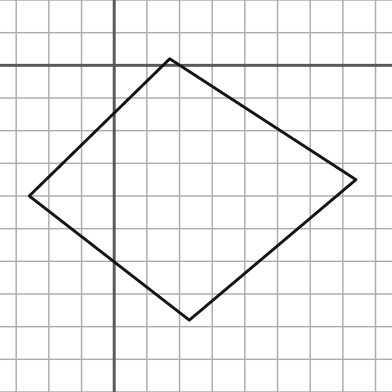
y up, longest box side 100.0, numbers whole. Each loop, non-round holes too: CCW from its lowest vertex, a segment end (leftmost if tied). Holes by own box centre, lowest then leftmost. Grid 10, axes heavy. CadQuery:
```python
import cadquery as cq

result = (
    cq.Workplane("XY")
    .moveTo(23.0, -78.0)
    .lineTo(74.0, -35.0)
    .lineTo(17.0, 2.0)
    .lineTo(-26.0, -40.0)
    .close()
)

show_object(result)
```